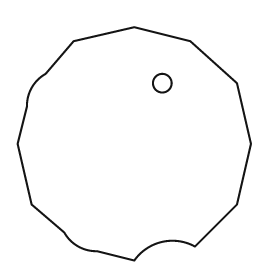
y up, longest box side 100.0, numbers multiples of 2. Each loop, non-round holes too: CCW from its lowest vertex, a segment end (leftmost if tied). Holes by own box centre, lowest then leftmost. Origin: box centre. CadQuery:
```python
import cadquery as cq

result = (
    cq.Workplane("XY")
    .moveTo(0.0, -50.0)
    .threePointArc((12.0, -42.0), (26.0, -44.0))
    .lineTo(44.0, -26.0)
    .lineTo(50.0, 0.0)
    .lineTo(44.0, 26.0)
    .lineTo(24.0, 44.0)
    .lineTo(0.0, 50.0)
    .lineTo(-26.0, 44.0)
    .lineTo(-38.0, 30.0)
    .threePointArc((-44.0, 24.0), (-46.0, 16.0))
    .lineTo(-50.0, 0.0)
    .lineTo(-44.0, -26.0)
    .lineTo(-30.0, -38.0)
    .threePointArc((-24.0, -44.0), (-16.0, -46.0))
    .close()
    .moveTo(12.0, 26.0)
    .circle(4.0)
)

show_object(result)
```